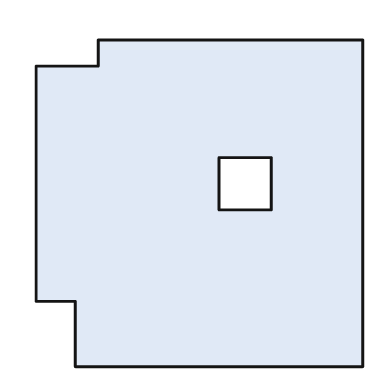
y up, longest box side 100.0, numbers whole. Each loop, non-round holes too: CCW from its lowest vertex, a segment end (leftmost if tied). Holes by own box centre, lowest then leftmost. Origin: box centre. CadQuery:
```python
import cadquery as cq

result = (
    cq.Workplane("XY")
    .moveTo(-38.0, -50.0)
    .lineTo(50.0, -50.0)
    .lineTo(50.0, 50.0)
    .lineTo(-31.0, 50.0)
    .lineTo(-31.0, 42.0)
    .lineTo(-50.0, 42.0)
    .lineTo(-50.0, -30.0)
    .lineTo(-38.0, -30.0)
    .close()
    .moveTo(6.0, -2.0)
    .lineTo(22.0, -2.0)
    .lineTo(22.0, 14.0)
    .lineTo(6.0, 14.0)
    .close()
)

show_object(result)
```